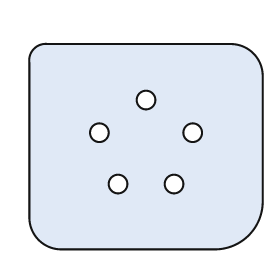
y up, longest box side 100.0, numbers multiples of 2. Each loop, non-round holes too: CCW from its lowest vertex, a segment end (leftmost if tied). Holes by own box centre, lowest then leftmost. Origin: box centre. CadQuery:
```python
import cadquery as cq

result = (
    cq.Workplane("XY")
    .moveTo(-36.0, -44.0)
    .lineTo(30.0, -44.0)
    .threePointArc((44.0, -38.0), (50.0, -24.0))
    .lineTo(50.0, 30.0)
    .threePointArc((46.0, 40.0), (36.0, 44.0))
    .lineTo(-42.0, 44.0)
    .threePointArc((-48.0, 42.0), (-50.0, 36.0))
    .lineTo(-50.0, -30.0)
    .threePointArc((-46.0, -40.0), (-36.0, -44.0))
    .close()
    .moveTo(-12.0, -16.0)
    .circle(4.0)
    .moveTo(12.0, -16.0)
    .circle(4.0)
    .moveTo(-20.0, 6.0)
    .circle(4.0)
    .moveTo(20.0, 6.0)
    .circle(4.0)
    .moveTo(0.0, 20.0)
    .circle(4.0)
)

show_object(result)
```